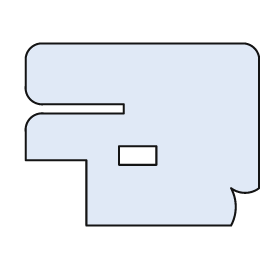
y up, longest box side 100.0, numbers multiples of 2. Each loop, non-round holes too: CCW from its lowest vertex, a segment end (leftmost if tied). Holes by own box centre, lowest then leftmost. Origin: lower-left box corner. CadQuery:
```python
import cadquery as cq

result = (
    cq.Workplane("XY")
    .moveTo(26.0, 0.0)
    .lineTo(88.0, 0.0)
    .threePointArc((90.0, 8.0), (88.0, 16.0))
    .threePointArc((94.0, 14.0), (100.0, 16.0))
    .lineTo(100.0, 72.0)
    .threePointArc((98.0, 76.0), (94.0, 78.0))
    .lineTo(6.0, 78.0)
    .threePointArc((2.0, 76.0), (0.0, 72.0))
    .lineTo(0.0, 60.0)
    .threePointArc((2.0, 54.0), (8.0, 52.0))
    .lineTo(42.0, 52.0)
    .lineTo(42.0, 48.0)
    .lineTo(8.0, 48.0)
    .threePointArc((2.0, 46.0), (0.0, 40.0))
    .lineTo(0.0, 28.0)
    .lineTo(26.0, 28.0)
    .close()
    .moveTo(40.0, 26.0)
    .lineTo(56.0, 26.0)
    .lineTo(56.0, 34.0)
    .lineTo(40.0, 34.0)
    .close()
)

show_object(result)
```